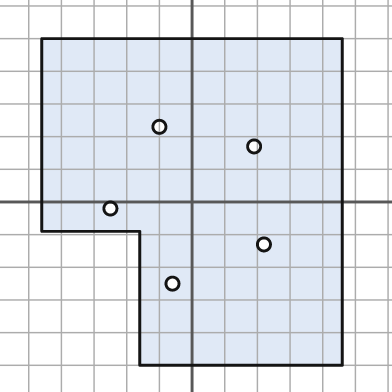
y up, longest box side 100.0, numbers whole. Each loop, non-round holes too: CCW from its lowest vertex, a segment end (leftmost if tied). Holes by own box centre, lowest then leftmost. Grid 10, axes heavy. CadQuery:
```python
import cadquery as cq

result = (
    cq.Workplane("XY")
    .moveTo(-16.0, -50.0)
    .lineTo(46.0, -50.0)
    .lineTo(46.0, 50.0)
    .lineTo(-46.0, 50.0)
    .lineTo(-46.0, -9.0)
    .lineTo(-16.0, -9.0)
    .close()
    .moveTo(-6.0, -25.0)
    .circle(2.0)
    .moveTo(22.0, -13.0)
    .circle(2.0)
    .moveTo(-25.0, -2.0)
    .circle(2.0)
    .moveTo(19.0, 17.0)
    .circle(2.0)
    .moveTo(-10.0, 23.0)
    .circle(2.0)
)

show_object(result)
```